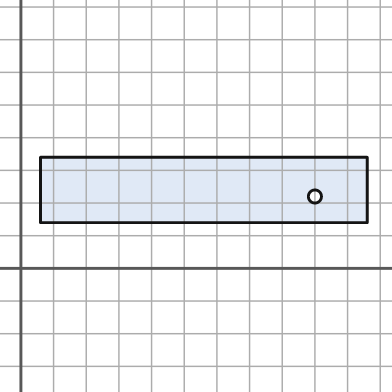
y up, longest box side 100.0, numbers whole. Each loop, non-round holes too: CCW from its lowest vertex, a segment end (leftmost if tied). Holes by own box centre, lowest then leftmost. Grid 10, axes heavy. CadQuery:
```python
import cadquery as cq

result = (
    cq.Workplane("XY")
    .moveTo(6.0, 14.0)
    .lineTo(106.0, 14.0)
    .lineTo(106.0, 34.0)
    .lineTo(6.0, 34.0)
    .close()
    .moveTo(90.0, 22.0)
    .circle(2.0)
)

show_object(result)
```